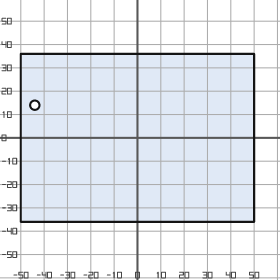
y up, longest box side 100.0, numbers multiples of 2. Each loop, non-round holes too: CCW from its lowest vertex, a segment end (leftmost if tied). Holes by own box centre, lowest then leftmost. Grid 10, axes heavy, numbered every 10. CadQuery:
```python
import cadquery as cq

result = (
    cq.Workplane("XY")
    .moveTo(-50.0, -36.0)
    .lineTo(50.0, -36.0)
    .lineTo(50.0, 36.0)
    .lineTo(-50.0, 36.0)
    .close()
    .moveTo(-44.0, 14.0)
    .circle(2.0)
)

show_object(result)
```